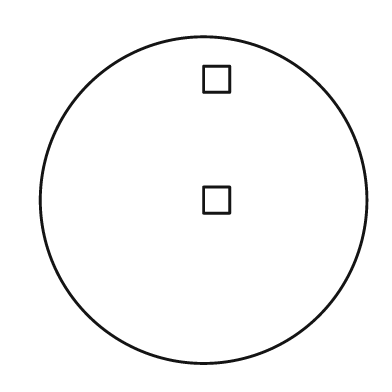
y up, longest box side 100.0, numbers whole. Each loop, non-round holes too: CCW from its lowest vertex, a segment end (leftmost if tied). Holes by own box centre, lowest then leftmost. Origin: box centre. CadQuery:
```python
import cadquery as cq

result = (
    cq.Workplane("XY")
    .moveTo(0.0, 0.0)
    .circle(50.0)
    .moveTo(0.0, -4.0)
    .lineTo(8.0, -4.0)
    .lineTo(8.0, 4.0)
    .lineTo(0.0, 4.0)
    .close()
    .moveTo(0.0, 33.0)
    .lineTo(8.0, 33.0)
    .lineTo(8.0, 41.0)
    .lineTo(0.0, 41.0)
    .close()
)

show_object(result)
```